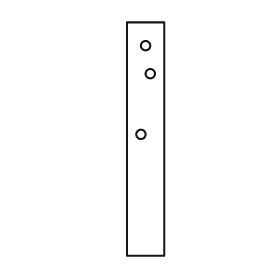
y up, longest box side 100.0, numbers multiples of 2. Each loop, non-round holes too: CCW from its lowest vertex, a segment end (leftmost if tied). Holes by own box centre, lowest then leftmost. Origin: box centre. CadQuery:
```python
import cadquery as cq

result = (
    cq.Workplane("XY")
    .moveTo(-8.0, -50.0)
    .lineTo(8.0, -50.0)
    .lineTo(8.0, 50.0)
    .lineTo(-8.0, 50.0)
    .close()
    .moveTo(-2.0, 2.0)
    .circle(2.0)
    .moveTo(2.0, 28.0)
    .circle(2.0)
    .moveTo(0.0, 40.0)
    .circle(2.0)
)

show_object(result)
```